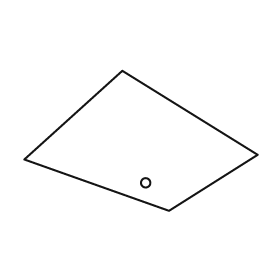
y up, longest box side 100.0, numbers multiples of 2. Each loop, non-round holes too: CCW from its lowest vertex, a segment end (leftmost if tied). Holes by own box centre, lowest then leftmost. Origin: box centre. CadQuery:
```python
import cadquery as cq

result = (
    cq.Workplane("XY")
    .moveTo(12.0, -30.0)
    .lineTo(50.0, -6.0)
    .lineTo(-8.0, 30.0)
    .lineTo(-50.0, -8.0)
    .close()
    .moveTo(2.0, -18.0)
    .circle(2.0)
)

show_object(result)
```